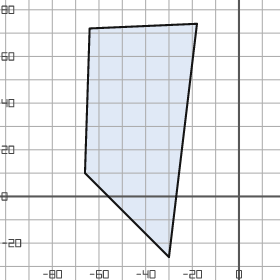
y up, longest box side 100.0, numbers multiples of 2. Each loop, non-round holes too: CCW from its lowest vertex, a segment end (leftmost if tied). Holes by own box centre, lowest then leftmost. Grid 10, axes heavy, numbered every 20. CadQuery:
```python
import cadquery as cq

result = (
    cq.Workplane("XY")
    .moveTo(-30.0, -26.0)
    .lineTo(-18.0, 74.0)
    .lineTo(-64.0, 72.0)
    .lineTo(-66.0, 10.0)
    .close()
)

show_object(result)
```